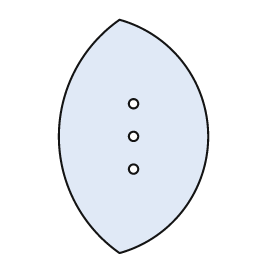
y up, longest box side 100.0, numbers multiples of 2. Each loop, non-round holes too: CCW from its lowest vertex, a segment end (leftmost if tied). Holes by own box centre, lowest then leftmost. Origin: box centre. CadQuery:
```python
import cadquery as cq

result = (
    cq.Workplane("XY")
    .moveTo(-6.0, -50.0)
    .threePointArc((32.0, 0.0), (-6.0, 50.0))
    .threePointArc((-32.0, 0.0), (-6.0, -50.0))
    .close()
    .moveTo(0.0, -14.0)
    .circle(2.0)
    .moveTo(0.0, 0.0)
    .circle(2.0)
    .moveTo(0.0, 14.0)
    .circle(2.0)
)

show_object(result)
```